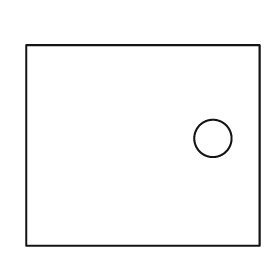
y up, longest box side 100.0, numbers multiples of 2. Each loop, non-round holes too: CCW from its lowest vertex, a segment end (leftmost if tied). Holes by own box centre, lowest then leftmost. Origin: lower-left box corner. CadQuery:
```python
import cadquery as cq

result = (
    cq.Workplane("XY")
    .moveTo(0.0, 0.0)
    .lineTo(100.0, 0.0)
    .lineTo(100.0, 86.0)
    .lineTo(0.0, 86.0)
    .close()
    .moveTo(80.0, 46.0)
    .circle(8.0)
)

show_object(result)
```